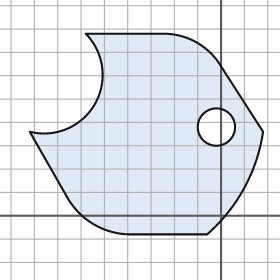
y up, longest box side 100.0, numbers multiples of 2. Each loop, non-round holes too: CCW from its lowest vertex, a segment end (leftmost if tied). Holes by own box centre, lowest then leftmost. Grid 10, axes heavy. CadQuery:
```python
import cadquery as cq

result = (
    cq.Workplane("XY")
    .moveTo(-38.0, -8.0)
    .lineTo(-6.0, -8.0)
    .threePointArc((10.0, 12.0), (18.0, 36.0))
    .lineTo(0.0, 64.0)
    .threePointArc((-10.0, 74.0), (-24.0, 78.0))
    .lineTo(-58.0, 78.0)
    .threePointArc((-54.0, 48.0), (-82.0, 36.0))
    .lineTo(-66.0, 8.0)
    .threePointArc((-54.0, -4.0), (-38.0, -8.0))
    .close()
    .moveTo(-2.0, 38.0)
    .circle(8.0)
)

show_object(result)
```